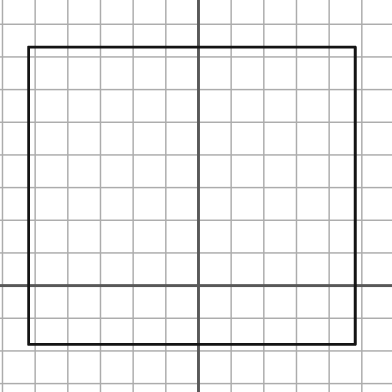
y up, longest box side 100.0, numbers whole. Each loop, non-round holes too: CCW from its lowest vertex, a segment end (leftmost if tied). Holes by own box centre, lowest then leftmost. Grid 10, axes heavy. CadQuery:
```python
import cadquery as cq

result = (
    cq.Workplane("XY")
    .moveTo(-52.0, -18.0)
    .lineTo(48.0, -18.0)
    .lineTo(48.0, 73.0)
    .lineTo(-52.0, 73.0)
    .close()
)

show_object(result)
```